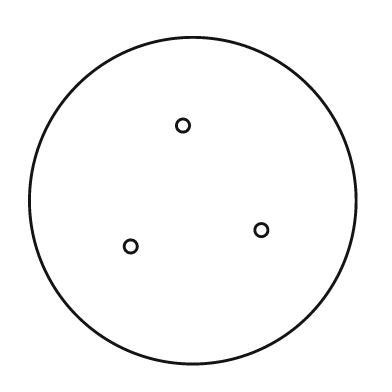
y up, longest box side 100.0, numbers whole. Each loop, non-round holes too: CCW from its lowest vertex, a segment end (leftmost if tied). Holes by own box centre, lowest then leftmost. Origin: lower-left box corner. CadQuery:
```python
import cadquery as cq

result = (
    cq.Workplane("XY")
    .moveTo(50.0, 50.0)
    .circle(50.0)
    .moveTo(31.0, 36.0)
    .circle(2.0)
    .moveTo(71.0, 41.0)
    .circle(2.0)
    .moveTo(47.0, 73.0)
    .circle(2.0)
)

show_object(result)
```